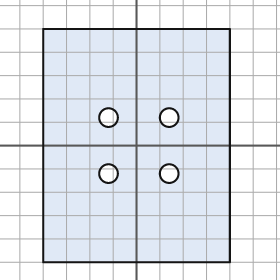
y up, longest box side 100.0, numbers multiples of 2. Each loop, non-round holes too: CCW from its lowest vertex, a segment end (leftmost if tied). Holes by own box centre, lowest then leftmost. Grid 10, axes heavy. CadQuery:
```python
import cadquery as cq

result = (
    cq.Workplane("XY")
    .moveTo(-40.0, -50.0)
    .lineTo(40.0, -50.0)
    .lineTo(40.0, 50.0)
    .lineTo(-40.0, 50.0)
    .close()
    .moveTo(-12.0, -12.0)
    .circle(4.0)
    .moveTo(14.0, -12.0)
    .circle(4.0)
    .moveTo(-12.0, 12.0)
    .circle(4.0)
    .moveTo(14.0, 12.0)
    .circle(4.0)
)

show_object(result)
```